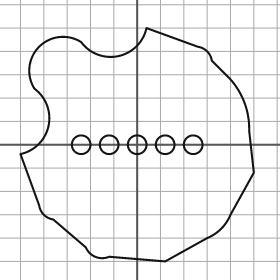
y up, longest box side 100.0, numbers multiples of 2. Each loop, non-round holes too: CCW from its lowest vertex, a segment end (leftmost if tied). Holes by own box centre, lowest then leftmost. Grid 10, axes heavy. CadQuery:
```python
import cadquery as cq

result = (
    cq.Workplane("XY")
    .moveTo(12.0, -50.0)
    .lineTo(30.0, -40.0)
    .threePointArc((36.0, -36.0), (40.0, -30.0))
    .lineTo(50.0, -12.0)
    .lineTo(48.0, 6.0)
    .threePointArc((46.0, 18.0), (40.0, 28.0))
    .lineTo(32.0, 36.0)
    .threePointArc((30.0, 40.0), (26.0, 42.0))
    .lineTo(4.0, 50.0)
    .threePointArc((-8.0, 38.0), (-24.0, 44.0))
    .threePointArc((-42.0, 42.0), (-44.0, 24.0))
    .threePointArc((-38.0, 8.0), (-50.0, -4.0))
    .lineTo(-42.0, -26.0)
    .threePointArc((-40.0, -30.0), (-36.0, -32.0))
    .lineTo(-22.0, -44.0)
    .threePointArc((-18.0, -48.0), (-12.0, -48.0))
    .close()
    .moveTo(-24.0, 0.0)
    .circle(4.0)
    .moveTo(-12.0, 0.0)
    .circle(4.0)
    .moveTo(0.0, 0.0)
    .circle(4.0)
    .moveTo(12.0, 0.0)
    .circle(4.0)
    .moveTo(24.0, 0.0)
    .circle(4.0)
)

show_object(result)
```